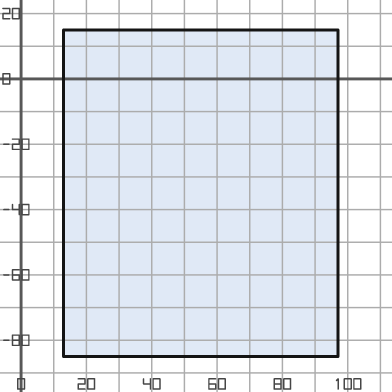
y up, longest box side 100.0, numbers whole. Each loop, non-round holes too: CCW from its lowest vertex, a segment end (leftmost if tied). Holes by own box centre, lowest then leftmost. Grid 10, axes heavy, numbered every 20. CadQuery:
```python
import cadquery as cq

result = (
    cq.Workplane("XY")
    .moveTo(13.0, -85.0)
    .lineTo(97.0, -85.0)
    .lineTo(97.0, 15.0)
    .lineTo(13.0, 15.0)
    .close()
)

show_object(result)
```